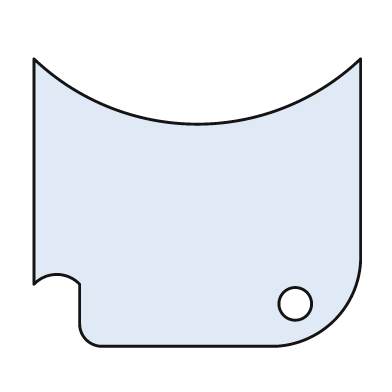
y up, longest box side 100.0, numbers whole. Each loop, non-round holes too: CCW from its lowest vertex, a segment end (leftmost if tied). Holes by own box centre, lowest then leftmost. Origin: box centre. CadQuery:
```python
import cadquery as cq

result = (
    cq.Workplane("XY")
    .moveTo(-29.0, -44.0)
    .lineTo(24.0, -44.0)
    .threePointArc((42.0, -36.0), (50.0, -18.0))
    .lineTo(50.0, 44.0)
    .threePointArc((0.0, 24.0), (-50.0, 44.0))
    .lineTo(-50.0, -25.0)
    .threePointArc((-43.0, -22.0), (-36.0, -25.0))
    .lineTo(-36.0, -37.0)
    .threePointArc((-34.0, -42.0), (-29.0, -44.0))
    .close()
    .moveTo(30.0, -31.0)
    .circle(5.0)
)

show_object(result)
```